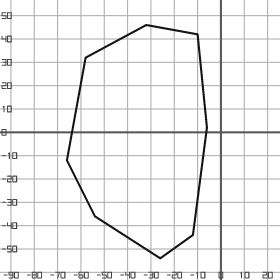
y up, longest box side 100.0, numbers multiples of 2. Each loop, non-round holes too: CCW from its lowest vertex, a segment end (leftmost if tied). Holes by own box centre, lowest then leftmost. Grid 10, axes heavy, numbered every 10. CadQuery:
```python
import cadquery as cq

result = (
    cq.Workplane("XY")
    .moveTo(-26.0, -54.0)
    .lineTo(-12.0, -44.0)
    .lineTo(-6.0, 2.0)
    .lineTo(-10.0, 42.0)
    .lineTo(-32.0, 46.0)
    .lineTo(-58.0, 32.0)
    .lineTo(-66.0, -12.0)
    .lineTo(-54.0, -36.0)
    .close()
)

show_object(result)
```